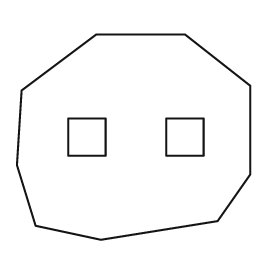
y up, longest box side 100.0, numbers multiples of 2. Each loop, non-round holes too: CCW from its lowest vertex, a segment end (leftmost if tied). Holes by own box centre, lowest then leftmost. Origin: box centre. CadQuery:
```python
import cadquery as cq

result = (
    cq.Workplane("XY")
    .moveTo(-14.0, -44.0)
    .lineTo(36.0, -36.0)
    .lineTo(50.0, -16.0)
    .lineTo(50.0, 22.0)
    .lineTo(22.0, 44.0)
    .lineTo(-16.0, 44.0)
    .lineTo(-48.0, 20.0)
    .lineTo(-50.0, -12.0)
    .lineTo(-42.0, -38.0)
    .close()
    .moveTo(-28.0, -8.0)
    .lineTo(-12.0, -8.0)
    .lineTo(-12.0, 8.0)
    .lineTo(-28.0, 8.0)
    .close()
    .moveTo(14.0, -8.0)
    .lineTo(30.0, -8.0)
    .lineTo(30.0, 8.0)
    .lineTo(14.0, 8.0)
    .close()
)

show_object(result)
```